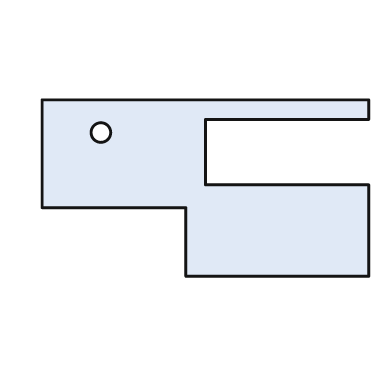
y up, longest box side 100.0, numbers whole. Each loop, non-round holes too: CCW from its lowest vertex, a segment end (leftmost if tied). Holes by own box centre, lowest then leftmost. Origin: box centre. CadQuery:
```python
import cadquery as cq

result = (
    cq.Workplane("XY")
    .moveTo(-6.0, -27.0)
    .lineTo(50.0, -27.0)
    .lineTo(50.0, 1.0)
    .lineTo(0.0, 1.0)
    .lineTo(0.0, 21.0)
    .lineTo(50.0, 21.0)
    .lineTo(50.0, 27.0)
    .lineTo(-50.0, 27.0)
    .lineTo(-50.0, -6.0)
    .lineTo(-6.0, -6.0)
    .close()
    .moveTo(-32.0, 17.0)
    .circle(3.0)
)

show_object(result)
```